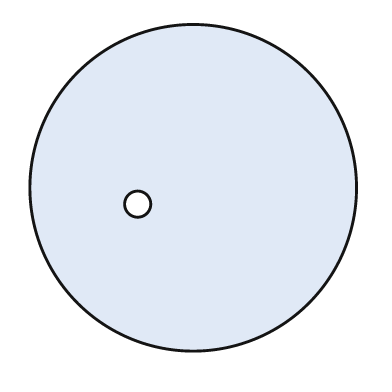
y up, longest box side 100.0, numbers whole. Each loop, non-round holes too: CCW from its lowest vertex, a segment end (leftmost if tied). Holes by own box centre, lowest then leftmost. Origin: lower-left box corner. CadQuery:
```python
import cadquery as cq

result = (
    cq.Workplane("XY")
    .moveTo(50.0, 50.0)
    .circle(50.0)
    .moveTo(33.0, 45.0)
    .circle(4.0)
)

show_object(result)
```